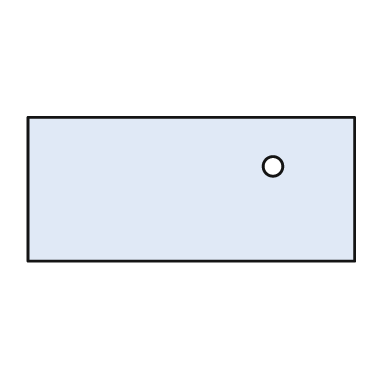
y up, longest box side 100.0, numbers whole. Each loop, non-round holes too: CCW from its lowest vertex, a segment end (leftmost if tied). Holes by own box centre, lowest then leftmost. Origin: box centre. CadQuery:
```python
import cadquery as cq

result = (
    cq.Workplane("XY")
    .moveTo(-50.0, -22.0)
    .lineTo(50.0, -22.0)
    .lineTo(50.0, 22.0)
    .lineTo(-50.0, 22.0)
    .close()
    .moveTo(25.0, 7.0)
    .circle(3.0)
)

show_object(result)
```